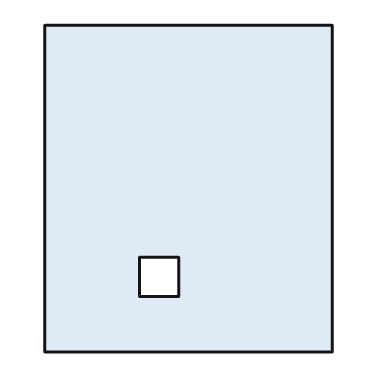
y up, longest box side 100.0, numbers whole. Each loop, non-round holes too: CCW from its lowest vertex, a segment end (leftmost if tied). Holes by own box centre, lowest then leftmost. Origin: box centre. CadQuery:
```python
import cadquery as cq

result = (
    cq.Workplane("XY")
    .moveTo(-44.0, -50.0)
    .lineTo(44.0, -50.0)
    .lineTo(44.0, 50.0)
    .lineTo(-44.0, 50.0)
    .close()
    .moveTo(-15.0, -33.0)
    .lineTo(-3.0, -33.0)
    .lineTo(-3.0, -21.0)
    .lineTo(-15.0, -21.0)
    .close()
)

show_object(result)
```